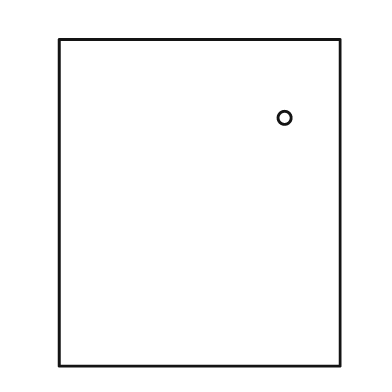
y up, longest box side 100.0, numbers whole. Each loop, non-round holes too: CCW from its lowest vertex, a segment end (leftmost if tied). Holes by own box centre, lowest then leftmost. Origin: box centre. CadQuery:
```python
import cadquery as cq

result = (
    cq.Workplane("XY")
    .moveTo(-43.0, -50.0)
    .lineTo(43.0, -50.0)
    .lineTo(43.0, 50.0)
    .lineTo(-43.0, 50.0)
    .close()
    .moveTo(26.0, 26.0)
    .circle(2.0)
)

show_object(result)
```